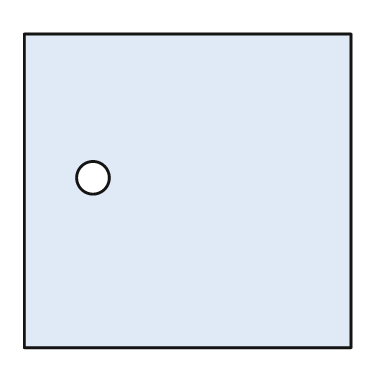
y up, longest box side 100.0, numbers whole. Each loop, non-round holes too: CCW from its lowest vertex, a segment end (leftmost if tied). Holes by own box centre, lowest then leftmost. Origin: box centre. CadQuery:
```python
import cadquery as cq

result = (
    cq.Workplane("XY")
    .moveTo(-50.0, -48.0)
    .lineTo(50.0, -48.0)
    .lineTo(50.0, 48.0)
    .lineTo(-50.0, 48.0)
    .close()
    .moveTo(-29.0, 4.0)
    .circle(5.0)
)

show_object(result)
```